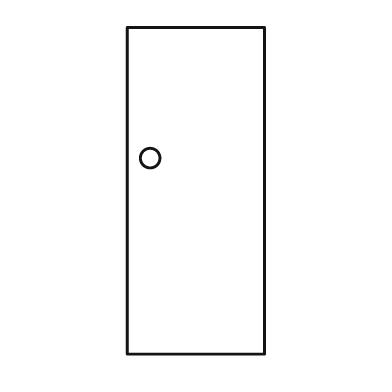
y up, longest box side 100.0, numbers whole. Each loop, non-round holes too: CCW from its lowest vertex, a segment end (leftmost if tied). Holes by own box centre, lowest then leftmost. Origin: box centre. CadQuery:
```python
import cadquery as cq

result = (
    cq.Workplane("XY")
    .moveTo(-21.0, -50.0)
    .lineTo(21.0, -50.0)
    .lineTo(21.0, 50.0)
    .lineTo(-21.0, 50.0)
    .close()
    .moveTo(-14.0, 10.0)
    .circle(3.0)
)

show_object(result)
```